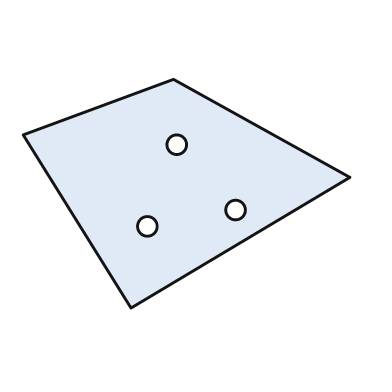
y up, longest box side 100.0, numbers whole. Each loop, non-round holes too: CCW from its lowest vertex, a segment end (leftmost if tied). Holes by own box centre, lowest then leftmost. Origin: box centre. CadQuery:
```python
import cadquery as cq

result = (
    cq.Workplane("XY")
    .moveTo(-17.0, -35.0)
    .lineTo(50.0, 5.0)
    .lineTo(-4.0, 35.0)
    .lineTo(-50.0, 18.0)
    .close()
    .moveTo(-12.0, -10.0)
    .circle(3.0)
    .moveTo(15.0, -5.0)
    .circle(3.0)
    .moveTo(-3.0, 15.0)
    .circle(3.0)
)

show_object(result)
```